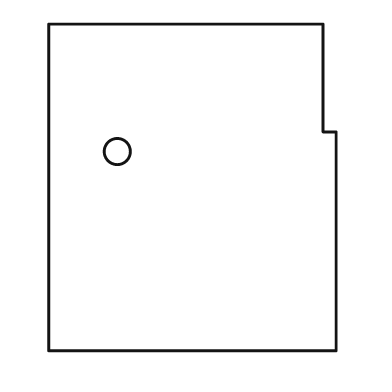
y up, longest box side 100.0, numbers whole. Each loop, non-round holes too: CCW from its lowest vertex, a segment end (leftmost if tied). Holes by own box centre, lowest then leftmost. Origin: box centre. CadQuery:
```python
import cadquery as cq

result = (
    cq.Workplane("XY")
    .moveTo(-44.0, -50.0)
    .lineTo(44.0, -50.0)
    .lineTo(44.0, 17.0)
    .lineTo(40.0, 17.0)
    .lineTo(40.0, 50.0)
    .lineTo(-44.0, 50.0)
    .close()
    .moveTo(-23.0, 11.0)
    .circle(4.0)
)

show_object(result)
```